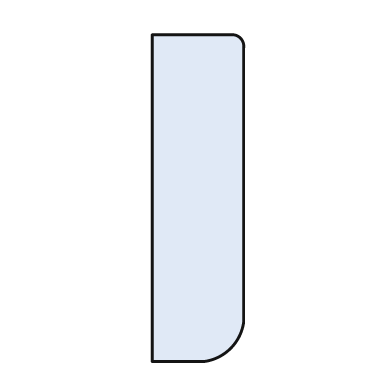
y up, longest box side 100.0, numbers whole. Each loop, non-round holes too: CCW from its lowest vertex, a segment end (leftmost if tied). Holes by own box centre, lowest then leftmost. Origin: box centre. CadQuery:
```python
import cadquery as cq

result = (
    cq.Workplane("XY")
    .moveTo(-14.0, -50.0)
    .lineTo(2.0, -50.0)
    .threePointArc((10.0, -46.0), (14.0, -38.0))
    .lineTo(14.0, 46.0)
    .threePointArc((13.0, 49.0), (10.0, 50.0))
    .lineTo(-14.0, 50.0)
    .close()
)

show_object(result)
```